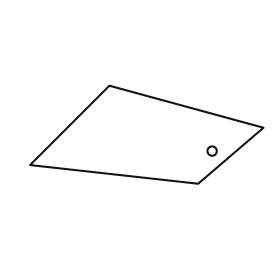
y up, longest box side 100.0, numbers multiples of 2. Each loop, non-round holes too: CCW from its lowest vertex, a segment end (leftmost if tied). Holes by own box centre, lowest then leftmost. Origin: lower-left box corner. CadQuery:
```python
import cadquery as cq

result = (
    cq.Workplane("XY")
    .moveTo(72.0, 0.0)
    .lineTo(100.0, 24.0)
    .lineTo(34.0, 42.0)
    .lineTo(0.0, 8.0)
    .close()
    .moveTo(78.0, 14.0)
    .circle(2.0)
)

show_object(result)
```